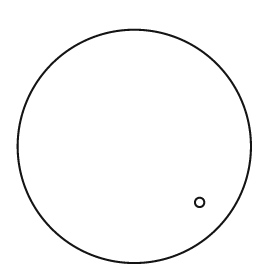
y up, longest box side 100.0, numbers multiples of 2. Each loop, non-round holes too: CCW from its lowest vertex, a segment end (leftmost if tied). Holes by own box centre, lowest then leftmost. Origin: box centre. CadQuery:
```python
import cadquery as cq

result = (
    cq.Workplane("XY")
    .moveTo(0.0, 0.0)
    .circle(50.0)
    .moveTo(28.0, -24.0)
    .circle(2.0)
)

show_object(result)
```